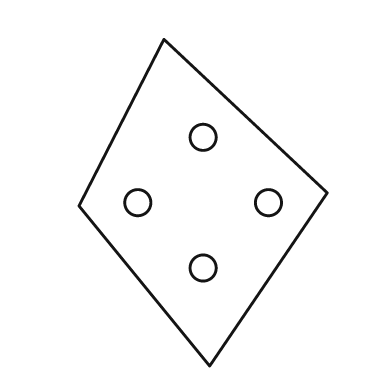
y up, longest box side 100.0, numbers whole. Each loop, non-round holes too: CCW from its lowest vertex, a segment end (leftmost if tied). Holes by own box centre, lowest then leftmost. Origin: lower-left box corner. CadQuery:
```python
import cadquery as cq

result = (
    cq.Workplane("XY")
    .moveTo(40.0, 0.0)
    .lineTo(76.0, 53.0)
    .lineTo(26.0, 100.0)
    .lineTo(0.0, 49.0)
    .close()
    .moveTo(38.0, 30.0)
    .circle(4.0)
    .moveTo(18.0, 50.0)
    .circle(4.0)
    .moveTo(58.0, 50.0)
    .circle(4.0)
    .moveTo(38.0, 70.0)
    .circle(4.0)
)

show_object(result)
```